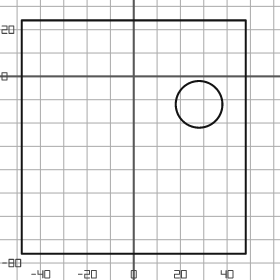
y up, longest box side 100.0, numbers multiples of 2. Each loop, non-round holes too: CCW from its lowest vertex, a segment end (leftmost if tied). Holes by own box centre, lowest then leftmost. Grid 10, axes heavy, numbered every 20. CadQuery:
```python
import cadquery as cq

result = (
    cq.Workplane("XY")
    .moveTo(-48.0, -76.0)
    .lineTo(48.0, -76.0)
    .lineTo(48.0, 24.0)
    .lineTo(-48.0, 24.0)
    .close()
    .moveTo(28.0, -12.0)
    .circle(10.0)
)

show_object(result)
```